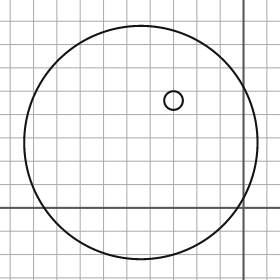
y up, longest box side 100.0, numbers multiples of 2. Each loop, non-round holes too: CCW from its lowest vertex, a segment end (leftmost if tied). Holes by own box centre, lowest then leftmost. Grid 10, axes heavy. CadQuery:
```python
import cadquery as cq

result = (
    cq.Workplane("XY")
    .moveTo(-44.0, 28.0)
    .circle(50.0)
    .moveTo(-30.0, 46.0)
    .circle(4.0)
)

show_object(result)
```